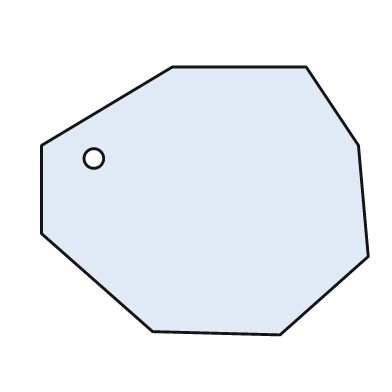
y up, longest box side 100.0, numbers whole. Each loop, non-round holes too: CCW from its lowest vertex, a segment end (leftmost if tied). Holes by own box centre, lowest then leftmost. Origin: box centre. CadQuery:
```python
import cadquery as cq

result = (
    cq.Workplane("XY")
    .moveTo(23.0, -41.0)
    .lineTo(50.0, -17.0)
    .lineTo(47.0, 17.0)
    .lineTo(31.0, 41.0)
    .lineTo(-10.0, 41.0)
    .lineTo(-50.0, 17.0)
    .lineTo(-50.0, -10.0)
    .lineTo(-16.0, -40.0)
    .close()
    .moveTo(-34.0, 13.0)
    .circle(3.0)
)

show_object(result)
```